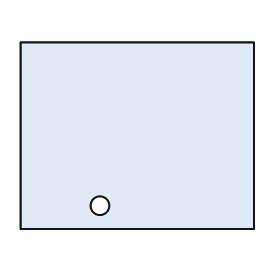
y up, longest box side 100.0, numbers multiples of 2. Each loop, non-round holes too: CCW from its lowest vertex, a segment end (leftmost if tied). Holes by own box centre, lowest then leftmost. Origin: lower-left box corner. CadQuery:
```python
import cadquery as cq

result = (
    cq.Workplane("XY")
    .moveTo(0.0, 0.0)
    .lineTo(100.0, 0.0)
    .lineTo(100.0, 80.0)
    .lineTo(0.0, 80.0)
    .close()
    .moveTo(34.0, 10.0)
    .circle(4.0)
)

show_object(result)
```